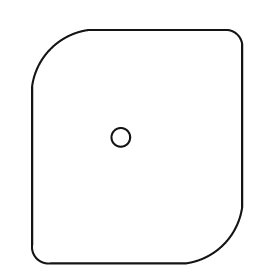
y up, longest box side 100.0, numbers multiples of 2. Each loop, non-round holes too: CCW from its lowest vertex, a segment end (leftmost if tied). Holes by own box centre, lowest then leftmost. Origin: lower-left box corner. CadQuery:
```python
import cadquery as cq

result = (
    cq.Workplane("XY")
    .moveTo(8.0, 0.0)
    .lineTo(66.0, 0.0)
    .threePointArc((82.0, 8.0), (90.0, 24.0))
    .lineTo(90.0, 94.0)
    .threePointArc((88.0, 98.0), (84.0, 100.0))
    .lineTo(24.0, 100.0)
    .threePointArc((8.0, 92.0), (0.0, 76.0))
    .lineTo(0.0, 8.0)
    .threePointArc((2.0, 2.0), (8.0, 0.0))
    .close()
    .moveTo(38.0, 54.0)
    .circle(4.0)
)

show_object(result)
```